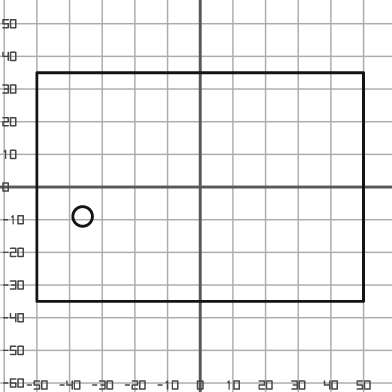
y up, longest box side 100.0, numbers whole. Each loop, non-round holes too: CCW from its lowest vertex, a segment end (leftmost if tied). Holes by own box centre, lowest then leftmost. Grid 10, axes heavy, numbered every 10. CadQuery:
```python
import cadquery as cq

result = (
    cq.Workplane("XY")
    .moveTo(-50.0, -35.0)
    .lineTo(50.0, -35.0)
    .lineTo(50.0, 35.0)
    .lineTo(-50.0, 35.0)
    .close()
    .moveTo(-36.0, -9.0)
    .circle(3.0)
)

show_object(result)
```